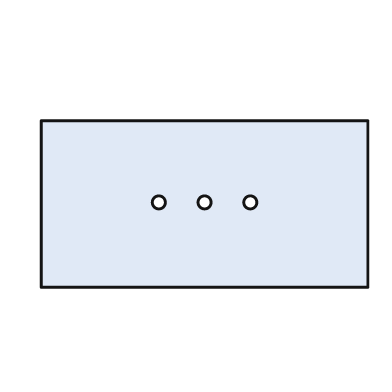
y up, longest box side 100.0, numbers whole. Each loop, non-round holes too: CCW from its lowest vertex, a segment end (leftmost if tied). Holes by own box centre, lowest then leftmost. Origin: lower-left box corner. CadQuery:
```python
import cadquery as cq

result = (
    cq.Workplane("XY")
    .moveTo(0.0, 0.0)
    .lineTo(100.0, 0.0)
    .lineTo(100.0, 51.0)
    .lineTo(0.0, 51.0)
    .close()
    .moveTo(36.0, 26.0)
    .circle(2.0)
    .moveTo(50.0, 26.0)
    .circle(2.0)
    .moveTo(64.0, 26.0)
    .circle(2.0)
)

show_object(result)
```